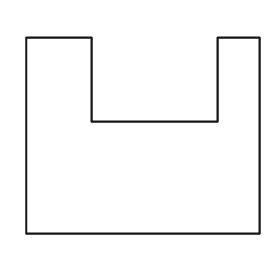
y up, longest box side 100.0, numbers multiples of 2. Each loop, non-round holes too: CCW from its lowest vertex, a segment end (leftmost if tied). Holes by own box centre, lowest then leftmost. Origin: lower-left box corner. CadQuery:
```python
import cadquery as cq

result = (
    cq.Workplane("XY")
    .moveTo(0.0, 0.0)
    .lineTo(100.0, 0.0)
    .lineTo(100.0, 84.0)
    .lineTo(82.0, 84.0)
    .lineTo(82.0, 48.0)
    .lineTo(28.0, 48.0)
    .lineTo(28.0, 84.0)
    .lineTo(0.0, 84.0)
    .close()
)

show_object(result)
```